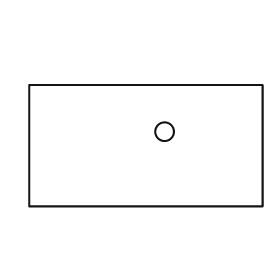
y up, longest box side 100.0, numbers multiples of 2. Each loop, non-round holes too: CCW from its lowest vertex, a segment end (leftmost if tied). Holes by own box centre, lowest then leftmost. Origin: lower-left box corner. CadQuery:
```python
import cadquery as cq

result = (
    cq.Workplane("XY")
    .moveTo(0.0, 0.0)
    .lineTo(100.0, 0.0)
    .lineTo(100.0, 52.0)
    .lineTo(0.0, 52.0)
    .close()
    .moveTo(58.0, 32.0)
    .circle(4.0)
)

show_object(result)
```